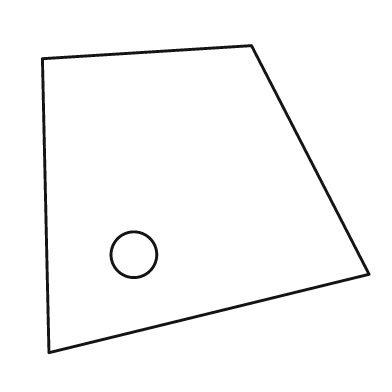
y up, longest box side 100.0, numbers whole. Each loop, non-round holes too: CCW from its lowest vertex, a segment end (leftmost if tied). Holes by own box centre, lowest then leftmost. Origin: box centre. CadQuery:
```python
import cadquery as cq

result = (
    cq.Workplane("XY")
    .moveTo(-48.0, -47.0)
    .lineTo(50.0, -23.0)
    .lineTo(14.0, 47.0)
    .lineTo(-50.0, 43.0)
    .close()
    .moveTo(-22.0, -17.0)
    .circle(7.0)
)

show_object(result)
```